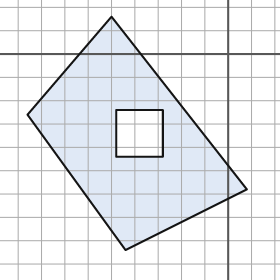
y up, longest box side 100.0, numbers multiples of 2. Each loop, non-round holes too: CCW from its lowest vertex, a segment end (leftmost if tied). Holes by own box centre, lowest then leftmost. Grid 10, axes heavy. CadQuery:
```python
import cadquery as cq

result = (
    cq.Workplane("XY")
    .moveTo(-44.0, -84.0)
    .lineTo(8.0, -58.0)
    .lineTo(-50.0, 16.0)
    .lineTo(-86.0, -26.0)
    .close()
    .moveTo(-48.0, -44.0)
    .lineTo(-28.0, -44.0)
    .lineTo(-28.0, -24.0)
    .lineTo(-48.0, -24.0)
    .close()
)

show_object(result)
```